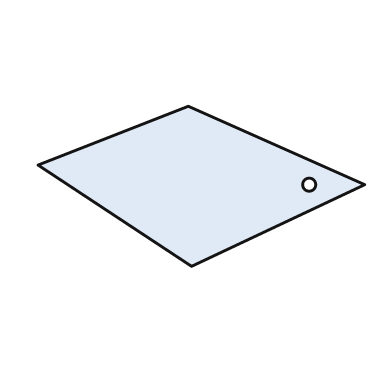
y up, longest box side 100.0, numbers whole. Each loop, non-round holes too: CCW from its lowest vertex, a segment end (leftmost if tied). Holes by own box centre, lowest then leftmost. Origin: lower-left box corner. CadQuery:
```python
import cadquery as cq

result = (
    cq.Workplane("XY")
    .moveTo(47.0, 0.0)
    .lineTo(100.0, 25.0)
    .lineTo(46.0, 49.0)
    .lineTo(0.0, 31.0)
    .close()
    .moveTo(83.0, 25.0)
    .circle(2.0)
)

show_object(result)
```